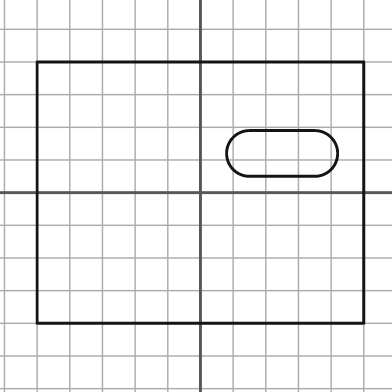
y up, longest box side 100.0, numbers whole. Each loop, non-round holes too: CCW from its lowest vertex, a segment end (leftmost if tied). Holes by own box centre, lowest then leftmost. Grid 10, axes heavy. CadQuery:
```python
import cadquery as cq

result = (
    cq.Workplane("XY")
    .moveTo(-50.0, -40.0)
    .lineTo(50.0, -40.0)
    .lineTo(50.0, 40.0)
    .lineTo(-50.0, 40.0)
    .close()
    .moveTo(15.0, 5.0)
    .lineTo(35.0, 5.0)
    .threePointArc((42.0, 12.0), (35.0, 19.0))
    .lineTo(15.0, 19.0)
    .threePointArc((8.0, 12.0), (15.0, 5.0))
    .close()
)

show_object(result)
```